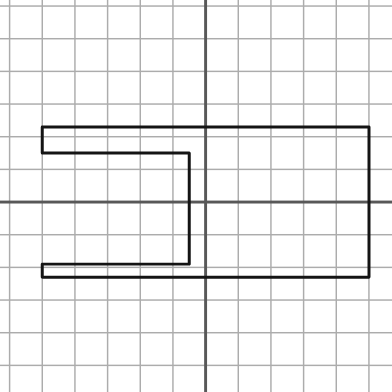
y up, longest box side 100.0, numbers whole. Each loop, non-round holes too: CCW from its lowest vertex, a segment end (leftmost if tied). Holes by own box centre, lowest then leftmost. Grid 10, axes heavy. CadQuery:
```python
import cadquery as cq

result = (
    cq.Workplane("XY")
    .moveTo(-50.0, -23.0)
    .lineTo(50.0, -23.0)
    .lineTo(50.0, 23.0)
    .lineTo(-50.0, 23.0)
    .lineTo(-50.0, 15.0)
    .lineTo(-5.0, 15.0)
    .lineTo(-5.0, -19.0)
    .lineTo(-50.0, -19.0)
    .close()
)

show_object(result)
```